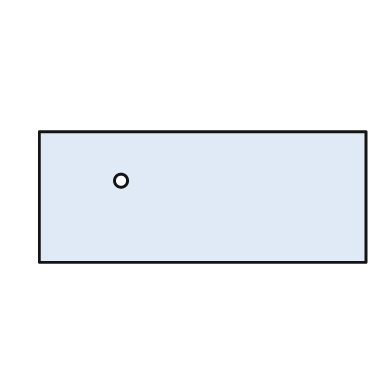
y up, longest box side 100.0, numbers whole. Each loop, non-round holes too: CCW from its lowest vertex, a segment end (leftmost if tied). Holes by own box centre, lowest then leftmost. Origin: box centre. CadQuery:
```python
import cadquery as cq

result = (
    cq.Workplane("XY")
    .moveTo(-50.0, -20.0)
    .lineTo(50.0, -20.0)
    .lineTo(50.0, 20.0)
    .lineTo(-50.0, 20.0)
    .close()
    .moveTo(-25.0, 5.0)
    .circle(2.0)
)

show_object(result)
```